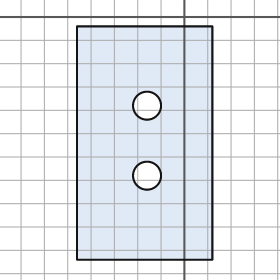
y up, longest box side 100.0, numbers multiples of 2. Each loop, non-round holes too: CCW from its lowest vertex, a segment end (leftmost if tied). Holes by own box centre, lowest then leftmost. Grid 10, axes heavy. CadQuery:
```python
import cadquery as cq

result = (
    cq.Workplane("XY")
    .moveTo(-46.0, -104.0)
    .lineTo(12.0, -104.0)
    .lineTo(12.0, -4.0)
    .lineTo(-46.0, -4.0)
    .close()
    .moveTo(-16.0, -68.0)
    .circle(6.0)
    .moveTo(-16.0, -38.0)
    .circle(6.0)
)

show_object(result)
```